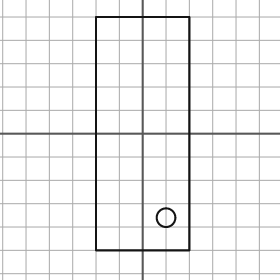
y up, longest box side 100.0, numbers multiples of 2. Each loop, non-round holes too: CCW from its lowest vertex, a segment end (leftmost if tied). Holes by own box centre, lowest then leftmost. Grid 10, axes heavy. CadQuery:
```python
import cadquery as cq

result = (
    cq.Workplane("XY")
    .moveTo(-20.0, -50.0)
    .lineTo(20.0, -50.0)
    .lineTo(20.0, 50.0)
    .lineTo(-20.0, 50.0)
    .close()
    .moveTo(10.0, -36.0)
    .circle(4.0)
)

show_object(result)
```